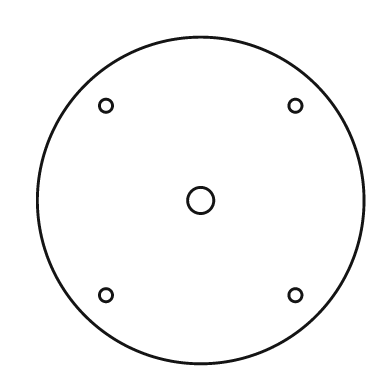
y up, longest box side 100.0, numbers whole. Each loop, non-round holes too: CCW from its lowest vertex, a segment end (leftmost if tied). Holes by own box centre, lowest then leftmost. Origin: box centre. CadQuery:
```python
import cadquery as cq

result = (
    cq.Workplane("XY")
    .moveTo(0.0, 0.0)
    .circle(50.0)
    .moveTo(-29.0, -29.0)
    .circle(2.0)
    .moveTo(29.0, -29.0)
    .circle(2.0)
    .moveTo(0.0, 0.0)
    .circle(4.0)
    .moveTo(-29.0, 29.0)
    .circle(2.0)
    .moveTo(29.0, 29.0)
    .circle(2.0)
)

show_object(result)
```